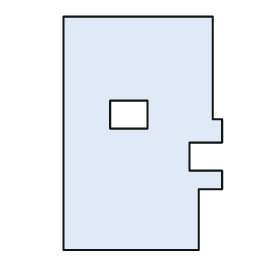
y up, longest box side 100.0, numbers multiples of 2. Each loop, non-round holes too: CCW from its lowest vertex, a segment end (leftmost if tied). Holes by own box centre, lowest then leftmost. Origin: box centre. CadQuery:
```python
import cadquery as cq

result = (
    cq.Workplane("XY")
    .moveTo(-34.0, -50.0)
    .lineTo(24.0, -50.0)
    .lineTo(24.0, -24.0)
    .lineTo(34.0, -24.0)
    .lineTo(34.0, -16.0)
    .lineTo(20.0, -16.0)
    .lineTo(20.0, -4.0)
    .lineTo(34.0, -4.0)
    .lineTo(34.0, 6.0)
    .lineTo(30.0, 6.0)
    .lineTo(30.0, 50.0)
    .lineTo(-34.0, 50.0)
    .close()
    .moveTo(-14.0, 2.0)
    .lineTo(2.0, 2.0)
    .lineTo(2.0, 14.0)
    .lineTo(-14.0, 14.0)
    .close()
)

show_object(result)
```